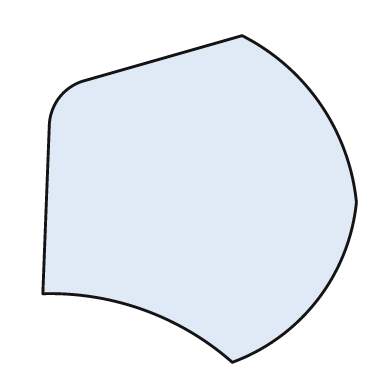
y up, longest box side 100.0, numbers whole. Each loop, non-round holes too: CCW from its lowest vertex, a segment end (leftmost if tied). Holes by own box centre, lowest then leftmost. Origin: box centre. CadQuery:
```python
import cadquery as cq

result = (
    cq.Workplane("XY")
    .moveTo(10.0, -50.0)
    .threePointArc((36.0, -31.0), (48.0, -1.0))
    .threePointArc((37.0, 29.0), (13.0, 50.0))
    .lineTo(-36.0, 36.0)
    .threePointArc((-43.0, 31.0), (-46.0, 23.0))
    .lineTo(-48.0, -29.0)
    .threePointArc((-17.0, -34.0), (10.0, -50.0))
    .close()
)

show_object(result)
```